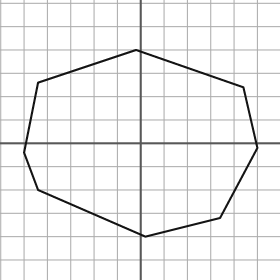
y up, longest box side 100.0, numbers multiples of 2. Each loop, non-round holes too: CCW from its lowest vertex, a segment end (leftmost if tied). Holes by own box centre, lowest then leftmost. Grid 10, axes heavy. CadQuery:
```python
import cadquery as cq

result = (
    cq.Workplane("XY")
    .moveTo(2.0, -40.0)
    .lineTo(34.0, -32.0)
    .lineTo(50.0, -2.0)
    .lineTo(44.0, 24.0)
    .lineTo(-2.0, 40.0)
    .lineTo(-44.0, 26.0)
    .lineTo(-50.0, -4.0)
    .lineTo(-44.0, -20.0)
    .close()
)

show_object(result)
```